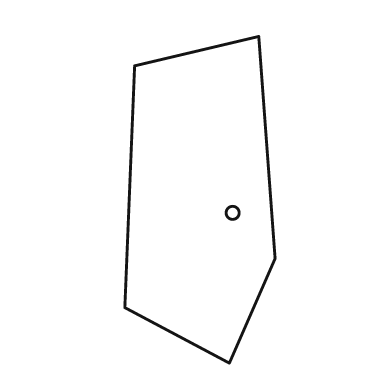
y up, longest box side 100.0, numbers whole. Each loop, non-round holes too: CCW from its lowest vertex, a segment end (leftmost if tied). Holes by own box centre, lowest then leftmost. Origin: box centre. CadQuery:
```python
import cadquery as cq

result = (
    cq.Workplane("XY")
    .moveTo(9.0, -50.0)
    .lineTo(23.0, -18.0)
    .lineTo(18.0, 50.0)
    .lineTo(-20.0, 41.0)
    .lineTo(-23.0, -33.0)
    .close()
    .moveTo(10.0, -4.0)
    .circle(2.0)
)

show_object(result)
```